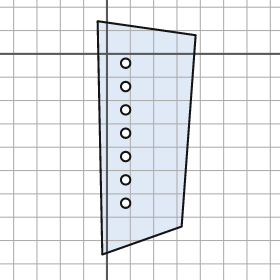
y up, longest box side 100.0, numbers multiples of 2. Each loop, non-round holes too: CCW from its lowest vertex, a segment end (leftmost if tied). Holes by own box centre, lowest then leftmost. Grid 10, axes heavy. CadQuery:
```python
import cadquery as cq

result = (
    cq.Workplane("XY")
    .moveTo(-2.0, -86.0)
    .lineTo(32.0, -74.0)
    .lineTo(38.0, 8.0)
    .lineTo(-4.0, 14.0)
    .close()
    .moveTo(8.0, -64.0)
    .circle(2.0)
    .moveTo(8.0, -54.0)
    .circle(2.0)
    .moveTo(8.0, -44.0)
    .circle(2.0)
    .moveTo(8.0, -34.0)
    .circle(2.0)
    .moveTo(8.0, -24.0)
    .circle(2.0)
    .moveTo(8.0, -14.0)
    .circle(2.0)
    .moveTo(8.0, -4.0)
    .circle(2.0)
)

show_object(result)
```